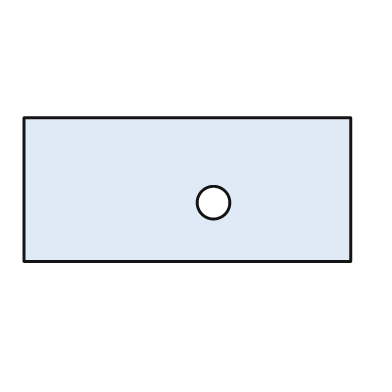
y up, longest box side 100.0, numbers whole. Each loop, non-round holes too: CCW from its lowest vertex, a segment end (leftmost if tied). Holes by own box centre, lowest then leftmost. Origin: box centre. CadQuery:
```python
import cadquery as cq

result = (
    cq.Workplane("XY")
    .moveTo(-50.0, -22.0)
    .lineTo(50.0, -22.0)
    .lineTo(50.0, 22.0)
    .lineTo(-50.0, 22.0)
    .close()
    .moveTo(8.0, -4.0)
    .circle(5.0)
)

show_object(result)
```